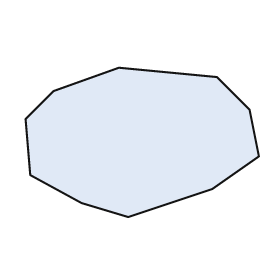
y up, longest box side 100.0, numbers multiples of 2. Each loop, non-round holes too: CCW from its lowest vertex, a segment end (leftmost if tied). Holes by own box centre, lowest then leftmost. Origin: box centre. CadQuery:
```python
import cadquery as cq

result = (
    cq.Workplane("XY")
    .moveTo(-6.0, -32.0)
    .lineTo(30.0, -20.0)
    .lineTo(50.0, -6.0)
    .lineTo(46.0, 14.0)
    .lineTo(32.0, 28.0)
    .lineTo(-10.0, 32.0)
    .lineTo(-38.0, 22.0)
    .lineTo(-50.0, 10.0)
    .lineTo(-48.0, -14.0)
    .lineTo(-26.0, -26.0)
    .close()
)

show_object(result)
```